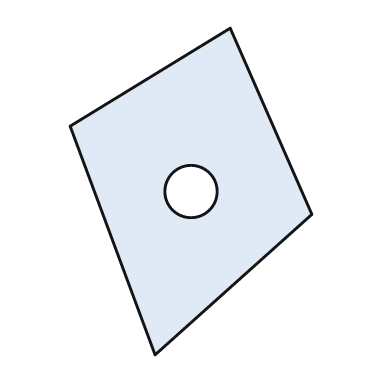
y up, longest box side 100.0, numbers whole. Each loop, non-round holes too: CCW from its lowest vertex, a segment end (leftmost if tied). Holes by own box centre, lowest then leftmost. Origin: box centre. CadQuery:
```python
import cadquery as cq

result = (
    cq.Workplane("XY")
    .moveTo(-11.0, -50.0)
    .lineTo(37.0, -7.0)
    .lineTo(12.0, 50.0)
    .lineTo(-37.0, 20.0)
    .close()
    .moveTo(0.0, 0.0)
    .circle(8.0)
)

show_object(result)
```